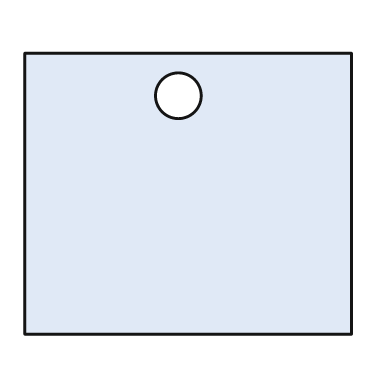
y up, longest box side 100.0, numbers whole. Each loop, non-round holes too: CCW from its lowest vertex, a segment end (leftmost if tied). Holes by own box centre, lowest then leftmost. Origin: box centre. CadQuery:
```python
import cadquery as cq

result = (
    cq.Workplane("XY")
    .moveTo(-50.0, -43.0)
    .lineTo(50.0, -43.0)
    .lineTo(50.0, 43.0)
    .lineTo(-50.0, 43.0)
    .close()
    .moveTo(-3.0, 30.0)
    .circle(7.0)
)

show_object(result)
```